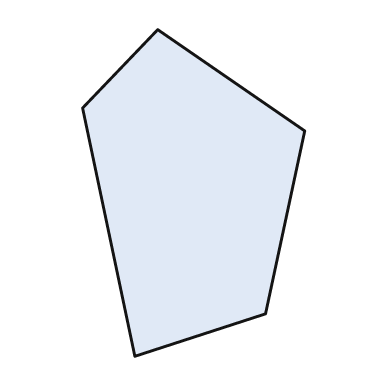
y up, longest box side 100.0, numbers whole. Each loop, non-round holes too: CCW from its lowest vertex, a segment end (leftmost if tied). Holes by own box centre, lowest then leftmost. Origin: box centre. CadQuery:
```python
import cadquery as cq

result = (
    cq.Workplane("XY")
    .moveTo(-18.0, -50.0)
    .lineTo(22.0, -37.0)
    .lineTo(34.0, 19.0)
    .lineTo(-11.0, 50.0)
    .lineTo(-34.0, 26.0)
    .close()
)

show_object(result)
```